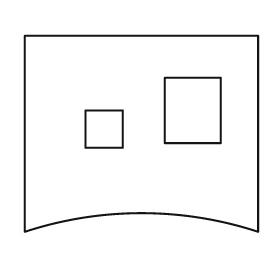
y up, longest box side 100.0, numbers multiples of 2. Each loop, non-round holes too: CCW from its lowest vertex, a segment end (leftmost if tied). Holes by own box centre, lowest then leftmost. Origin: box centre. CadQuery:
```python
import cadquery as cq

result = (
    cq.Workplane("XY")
    .moveTo(-50.0, -42.0)
    .threePointArc((0.0, -34.0), (50.0, -42.0))
    .lineTo(50.0, 42.0)
    .lineTo(-50.0, 42.0)
    .close()
    .moveTo(-24.0, -6.0)
    .lineTo(-8.0, -6.0)
    .lineTo(-8.0, 10.0)
    .lineTo(-24.0, 10.0)
    .close()
    .moveTo(10.0, -4.0)
    .lineTo(34.0, -4.0)
    .lineTo(34.0, 24.0)
    .lineTo(10.0, 24.0)
    .close()
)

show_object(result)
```